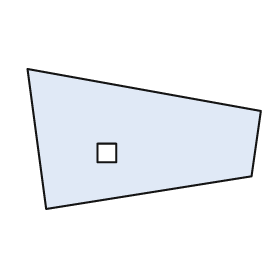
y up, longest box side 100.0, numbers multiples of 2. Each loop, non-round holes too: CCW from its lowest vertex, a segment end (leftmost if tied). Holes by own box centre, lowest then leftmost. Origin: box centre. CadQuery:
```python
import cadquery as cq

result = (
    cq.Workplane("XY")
    .moveTo(-42.0, -30.0)
    .lineTo(46.0, -16.0)
    .lineTo(50.0, 12.0)
    .lineTo(-50.0, 30.0)
    .close()
    .moveTo(-20.0, -10.0)
    .lineTo(-12.0, -10.0)
    .lineTo(-12.0, -2.0)
    .lineTo(-20.0, -2.0)
    .close()
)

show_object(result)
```